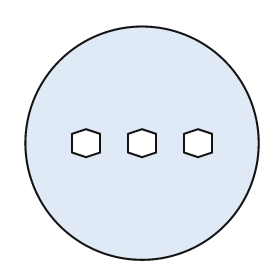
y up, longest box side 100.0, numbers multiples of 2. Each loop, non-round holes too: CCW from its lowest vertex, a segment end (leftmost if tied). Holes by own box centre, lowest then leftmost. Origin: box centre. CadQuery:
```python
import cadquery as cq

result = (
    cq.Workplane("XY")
    .moveTo(0.0, 0.0)
    .circle(50.0)
    .moveTo(-24.0, -6.0)
    .lineTo(-18.0, -4.0)
    .lineTo(-18.0, 4.0)
    .lineTo(-24.0, 6.0)
    .lineTo(-30.0, 4.0)
    .lineTo(-30.0, -4.0)
    .close()
    .moveTo(0.0, -6.0)
    .lineTo(6.0, -4.0)
    .lineTo(6.0, 4.0)
    .lineTo(0.0, 6.0)
    .lineTo(-6.0, 4.0)
    .lineTo(-6.0, -4.0)
    .close()
    .moveTo(24.0, -6.0)
    .lineTo(30.0, -4.0)
    .lineTo(30.0, 4.0)
    .lineTo(24.0, 6.0)
    .lineTo(18.0, 4.0)
    .lineTo(18.0, -4.0)
    .close()
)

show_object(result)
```